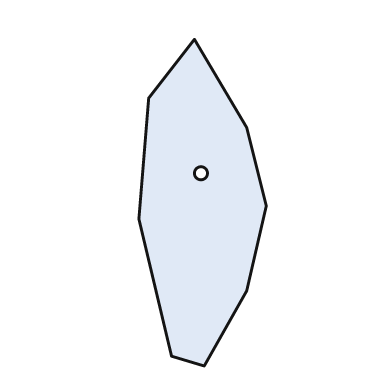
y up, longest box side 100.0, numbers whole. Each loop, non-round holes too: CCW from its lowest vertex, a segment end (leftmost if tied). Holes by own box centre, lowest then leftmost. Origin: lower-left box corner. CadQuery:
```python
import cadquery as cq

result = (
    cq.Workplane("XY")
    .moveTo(20.0, 0.0)
    .lineTo(33.0, 23.0)
    .lineTo(39.0, 49.0)
    .lineTo(33.0, 73.0)
    .lineTo(17.0, 100.0)
    .lineTo(3.0, 82.0)
    .lineTo(0.0, 45.0)
    .lineTo(10.0, 3.0)
    .close()
    .moveTo(19.0, 59.0)
    .circle(2.0)
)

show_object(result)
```